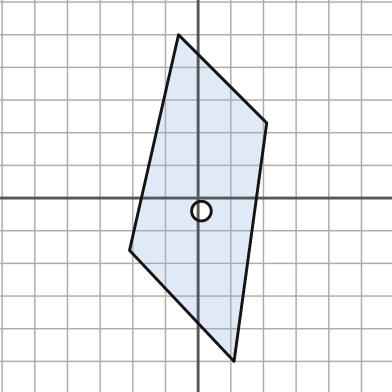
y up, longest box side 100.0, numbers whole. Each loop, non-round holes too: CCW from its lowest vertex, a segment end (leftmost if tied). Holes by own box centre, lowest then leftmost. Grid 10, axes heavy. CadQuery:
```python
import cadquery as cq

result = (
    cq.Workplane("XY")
    .moveTo(11.0, -50.0)
    .lineTo(21.0, 23.0)
    .lineTo(-6.0, 50.0)
    .lineTo(-21.0, -16.0)
    .close()
    .moveTo(1.0, -4.0)
    .circle(3.0)
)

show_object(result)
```